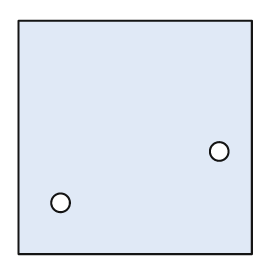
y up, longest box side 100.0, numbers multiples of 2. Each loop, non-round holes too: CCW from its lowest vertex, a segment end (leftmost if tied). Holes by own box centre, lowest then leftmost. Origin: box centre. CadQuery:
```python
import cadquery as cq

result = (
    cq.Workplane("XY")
    .moveTo(-50.0, -50.0)
    .lineTo(50.0, -50.0)
    .lineTo(50.0, 50.0)
    .lineTo(-50.0, 50.0)
    .close()
    .moveTo(-32.0, -28.0)
    .circle(4.0)
    .moveTo(36.0, -6.0)
    .circle(4.0)
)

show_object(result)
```